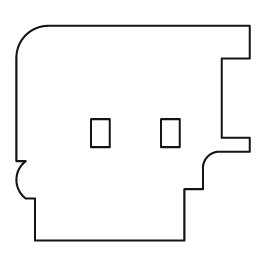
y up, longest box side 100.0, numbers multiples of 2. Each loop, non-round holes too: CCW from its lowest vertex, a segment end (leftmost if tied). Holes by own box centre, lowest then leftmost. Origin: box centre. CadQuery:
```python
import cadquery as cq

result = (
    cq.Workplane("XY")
    .moveTo(-42.0, -46.0)
    .lineTo(22.0, -46.0)
    .lineTo(22.0, -24.0)
    .lineTo(30.0, -24.0)
    .lineTo(30.0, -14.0)
    .threePointArc((32.0, -10.0), (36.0, -8.0))
    .lineTo(50.0, -8.0)
    .lineTo(50.0, -2.0)
    .lineTo(38.0, -2.0)
    .lineTo(38.0, 32.0)
    .lineTo(50.0, 32.0)
    .lineTo(50.0, 46.0)
    .lineTo(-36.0, 46.0)
    .threePointArc((-46.0, 42.0), (-50.0, 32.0))
    .lineTo(-50.0, -12.0)
    .lineTo(-46.0, -12.0)
    .threePointArc((-50.0, -20.0), (-46.0, -28.0))
    .lineTo(-42.0, -28.0)
    .close()
    .moveTo(-18.0, -6.0)
    .lineTo(-10.0, -6.0)
    .lineTo(-10.0, 6.0)
    .lineTo(-18.0, 6.0)
    .close()
    .moveTo(12.0, -6.0)
    .lineTo(20.0, -6.0)
    .lineTo(20.0, 6.0)
    .lineTo(12.0, 6.0)
    .close()
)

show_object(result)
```